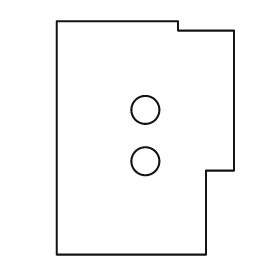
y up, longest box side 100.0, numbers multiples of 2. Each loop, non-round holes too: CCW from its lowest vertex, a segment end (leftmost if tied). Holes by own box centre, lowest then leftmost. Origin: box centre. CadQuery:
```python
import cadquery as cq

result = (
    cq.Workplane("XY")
    .moveTo(-38.0, -50.0)
    .lineTo(26.0, -50.0)
    .lineTo(26.0, -14.0)
    .lineTo(38.0, -14.0)
    .lineTo(38.0, 46.0)
    .lineTo(14.0, 46.0)
    .lineTo(14.0, 50.0)
    .lineTo(-38.0, 50.0)
    .close()
    .moveTo(0.0, -10.0)
    .circle(6.0)
    .moveTo(0.0, 12.0)
    .circle(6.0)
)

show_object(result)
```